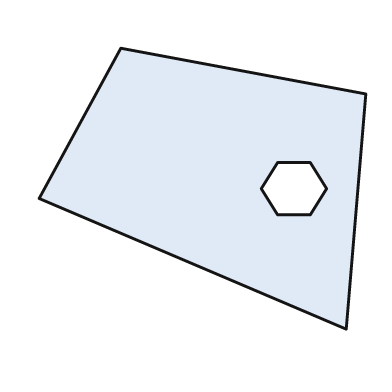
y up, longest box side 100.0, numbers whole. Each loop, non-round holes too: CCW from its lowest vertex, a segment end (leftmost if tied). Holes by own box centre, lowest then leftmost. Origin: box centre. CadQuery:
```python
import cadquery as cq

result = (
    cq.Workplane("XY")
    .moveTo(44.0, -43.0)
    .lineTo(50.0, 29.0)
    .lineTo(-25.0, 43.0)
    .lineTo(-50.0, -3.0)
    .close()
    .moveTo(23.0, -8.0)
    .lineTo(33.0, -8.0)
    .lineTo(38.0, 0.0)
    .lineTo(33.0, 8.0)
    .lineTo(23.0, 8.0)
    .lineTo(18.0, 0.0)
    .close()
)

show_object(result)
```